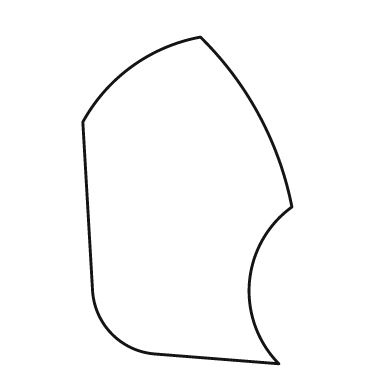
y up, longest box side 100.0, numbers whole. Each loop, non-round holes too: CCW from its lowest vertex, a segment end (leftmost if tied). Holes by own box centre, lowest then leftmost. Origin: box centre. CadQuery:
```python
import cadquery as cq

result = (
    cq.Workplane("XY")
    .moveTo(28.0, -50.0)
    .threePointArc((19.0, -25.0), (32.0, -2.0))
    .threePointArc((22.0, 26.0), (4.0, 50.0))
    .threePointArc((-17.0, 41.0), (-32.0, 24.0))
    .lineTo(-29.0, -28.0)
    .threePointArc((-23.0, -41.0), (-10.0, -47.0))
    .close()
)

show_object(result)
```